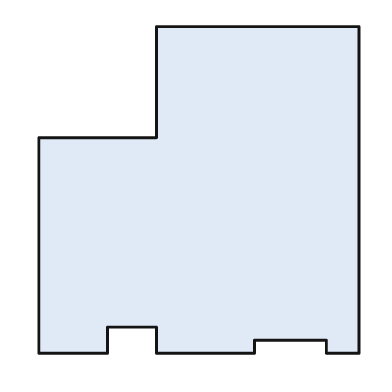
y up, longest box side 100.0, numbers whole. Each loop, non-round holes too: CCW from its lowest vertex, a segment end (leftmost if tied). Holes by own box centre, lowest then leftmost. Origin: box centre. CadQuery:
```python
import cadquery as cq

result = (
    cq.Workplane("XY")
    .moveTo(-49.0, -50.0)
    .lineTo(-28.0, -50.0)
    .lineTo(-28.0, -42.0)
    .lineTo(-13.0, -42.0)
    .lineTo(-13.0, -50.0)
    .lineTo(17.0, -50.0)
    .lineTo(17.0, -46.0)
    .lineTo(39.0, -46.0)
    .lineTo(39.0, -50.0)
    .lineTo(49.0, -50.0)
    .lineTo(49.0, 50.0)
    .lineTo(-13.0, 50.0)
    .lineTo(-13.0, 16.0)
    .lineTo(-49.0, 16.0)
    .close()
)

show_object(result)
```